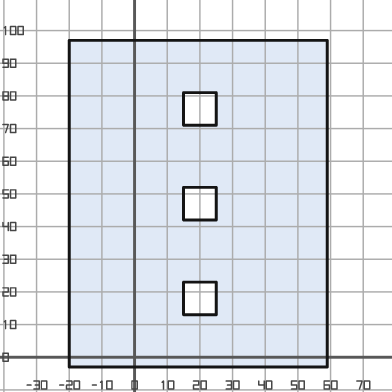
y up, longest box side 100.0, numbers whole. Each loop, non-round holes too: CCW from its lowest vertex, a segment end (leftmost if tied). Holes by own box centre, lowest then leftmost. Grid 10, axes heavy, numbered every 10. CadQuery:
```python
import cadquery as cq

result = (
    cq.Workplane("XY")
    .moveTo(-20.0, -3.0)
    .lineTo(59.0, -3.0)
    .lineTo(59.0, 97.0)
    .lineTo(-20.0, 97.0)
    .close()
    .moveTo(15.0, 13.0)
    .lineTo(25.0, 13.0)
    .lineTo(25.0, 23.0)
    .lineTo(15.0, 23.0)
    .close()
    .moveTo(15.0, 42.0)
    .lineTo(25.0, 42.0)
    .lineTo(25.0, 52.0)
    .lineTo(15.0, 52.0)
    .close()
    .moveTo(15.0, 71.0)
    .lineTo(25.0, 71.0)
    .lineTo(25.0, 81.0)
    .lineTo(15.0, 81.0)
    .close()
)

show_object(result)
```